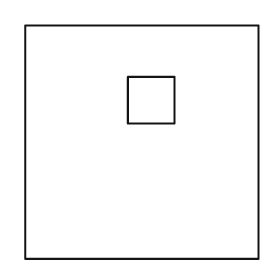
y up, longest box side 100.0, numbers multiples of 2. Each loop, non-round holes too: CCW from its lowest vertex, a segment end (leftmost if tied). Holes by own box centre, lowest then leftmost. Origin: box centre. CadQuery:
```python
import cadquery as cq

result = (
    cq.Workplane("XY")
    .moveTo(-50.0, -50.0)
    .lineTo(50.0, -50.0)
    .lineTo(50.0, 50.0)
    .lineTo(-50.0, 50.0)
    .close()
    .moveTo(-6.0, 8.0)
    .lineTo(14.0, 8.0)
    .lineTo(14.0, 28.0)
    .lineTo(-6.0, 28.0)
    .close()
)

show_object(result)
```